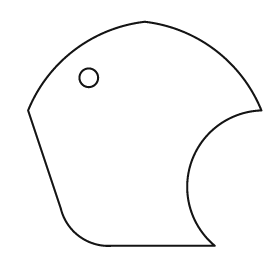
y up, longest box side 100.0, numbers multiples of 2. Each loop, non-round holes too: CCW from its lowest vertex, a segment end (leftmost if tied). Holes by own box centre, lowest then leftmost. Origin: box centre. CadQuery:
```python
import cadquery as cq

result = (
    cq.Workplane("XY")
    .moveTo(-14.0, -48.0)
    .lineTo(30.0, -48.0)
    .threePointArc((20.0, -12.0), (50.0, 10.0))
    .threePointArc((30.0, 36.0), (0.0, 48.0))
    .threePointArc((-30.0, 36.0), (-50.0, 10.0))
    .lineTo(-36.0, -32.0)
    .threePointArc((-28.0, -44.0), (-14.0, -48.0))
    .close()
    .moveTo(-24.0, 24.0)
    .circle(4.0)
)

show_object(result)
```